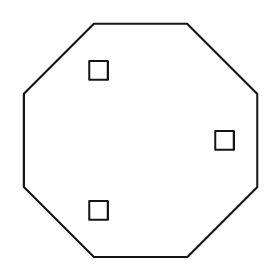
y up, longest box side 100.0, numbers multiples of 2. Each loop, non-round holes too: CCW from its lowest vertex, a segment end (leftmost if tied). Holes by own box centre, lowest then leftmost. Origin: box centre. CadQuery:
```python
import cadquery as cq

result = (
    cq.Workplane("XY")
    .moveTo(-20.0, -50.0)
    .lineTo(20.0, -50.0)
    .lineTo(50.0, -20.0)
    .lineTo(50.0, 20.0)
    .lineTo(20.0, 50.0)
    .lineTo(-20.0, 50.0)
    .lineTo(-50.0, 20.0)
    .lineTo(-50.0, -20.0)
    .close()
    .moveTo(-22.0, -34.0)
    .lineTo(-14.0, -34.0)
    .lineTo(-14.0, -26.0)
    .lineTo(-22.0, -26.0)
    .close()
    .moveTo(32.0, -4.0)
    .lineTo(40.0, -4.0)
    .lineTo(40.0, 4.0)
    .lineTo(32.0, 4.0)
    .close()
    .moveTo(-22.0, 26.0)
    .lineTo(-14.0, 26.0)
    .lineTo(-14.0, 34.0)
    .lineTo(-22.0, 34.0)
    .close()
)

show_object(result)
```